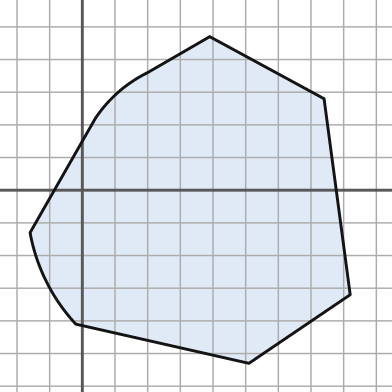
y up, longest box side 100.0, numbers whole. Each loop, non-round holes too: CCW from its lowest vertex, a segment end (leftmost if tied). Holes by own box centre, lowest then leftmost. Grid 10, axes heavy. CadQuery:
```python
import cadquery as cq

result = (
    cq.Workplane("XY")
    .moveTo(51.0, -53.0)
    .lineTo(82.0, -32.0)
    .lineTo(74.0, 28.0)
    .lineTo(39.0, 47.0)
    .lineTo(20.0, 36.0)
    .threePointArc((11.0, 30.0), (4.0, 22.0))
    .lineTo(-16.0, -13.0)
    .threePointArc((-11.0, -28.0), (-2.0, -41.0))
    .close()
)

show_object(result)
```